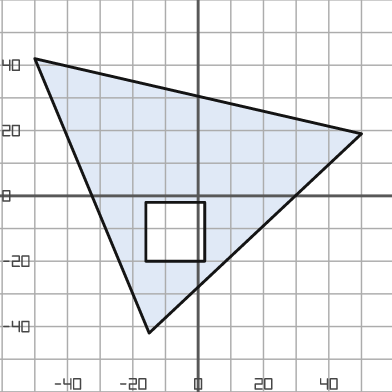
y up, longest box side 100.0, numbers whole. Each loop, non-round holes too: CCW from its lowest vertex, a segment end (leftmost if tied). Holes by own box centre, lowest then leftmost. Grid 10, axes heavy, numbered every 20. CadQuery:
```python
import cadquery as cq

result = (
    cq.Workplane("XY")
    .moveTo(-15.0, -42.0)
    .lineTo(50.0, 19.0)
    .lineTo(-50.0, 42.0)
    .close()
    .moveTo(-16.0, -20.0)
    .lineTo(2.0, -20.0)
    .lineTo(2.0, -2.0)
    .lineTo(-16.0, -2.0)
    .close()
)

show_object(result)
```